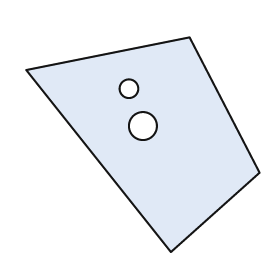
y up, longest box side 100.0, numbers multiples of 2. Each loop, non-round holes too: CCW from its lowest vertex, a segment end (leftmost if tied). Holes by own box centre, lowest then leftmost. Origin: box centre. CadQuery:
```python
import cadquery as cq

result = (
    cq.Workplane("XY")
    .moveTo(12.0, -46.0)
    .lineTo(50.0, -12.0)
    .lineTo(20.0, 46.0)
    .lineTo(-50.0, 32.0)
    .close()
    .moveTo(0.0, 8.0)
    .circle(6.0)
    .moveTo(-6.0, 24.0)
    .circle(4.0)
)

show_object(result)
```